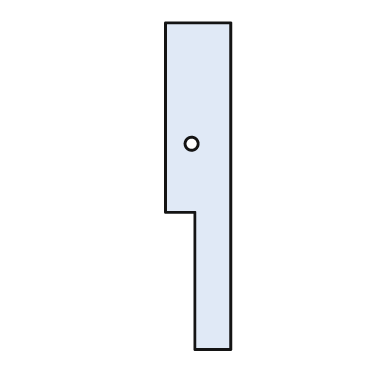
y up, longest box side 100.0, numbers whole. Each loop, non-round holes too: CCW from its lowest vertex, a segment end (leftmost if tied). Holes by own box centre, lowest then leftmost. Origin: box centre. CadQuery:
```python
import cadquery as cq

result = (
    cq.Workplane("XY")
    .moveTo(-1.0, -50.0)
    .lineTo(10.0, -50.0)
    .lineTo(10.0, 50.0)
    .lineTo(-10.0, 50.0)
    .lineTo(-10.0, -8.0)
    .lineTo(-1.0, -8.0)
    .close()
    .moveTo(-2.0, 13.0)
    .circle(2.0)
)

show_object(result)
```